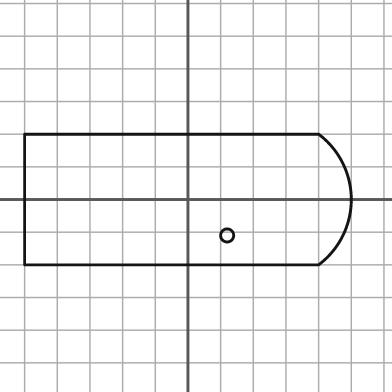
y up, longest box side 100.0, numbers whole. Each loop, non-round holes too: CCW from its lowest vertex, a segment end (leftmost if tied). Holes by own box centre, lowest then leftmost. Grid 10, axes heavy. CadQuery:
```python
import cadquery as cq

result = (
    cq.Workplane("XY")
    .moveTo(-50.0, -20.0)
    .lineTo(40.0, -20.0)
    .threePointArc((50.0, 0.0), (40.0, 20.0))
    .lineTo(-50.0, 20.0)
    .close()
    .moveTo(12.0, -11.0)
    .circle(2.0)
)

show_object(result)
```